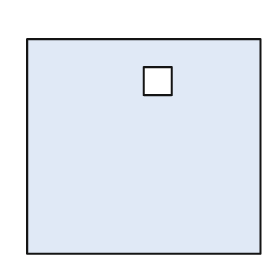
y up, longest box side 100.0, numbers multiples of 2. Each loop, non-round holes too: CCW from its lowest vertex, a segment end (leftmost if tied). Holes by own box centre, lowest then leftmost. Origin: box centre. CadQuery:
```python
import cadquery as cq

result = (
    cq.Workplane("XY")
    .moveTo(-50.0, -46.0)
    .lineTo(50.0, -46.0)
    .lineTo(50.0, 46.0)
    .lineTo(-50.0, 46.0)
    .close()
    .moveTo(0.0, 22.0)
    .lineTo(12.0, 22.0)
    .lineTo(12.0, 34.0)
    .lineTo(0.0, 34.0)
    .close()
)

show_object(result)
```